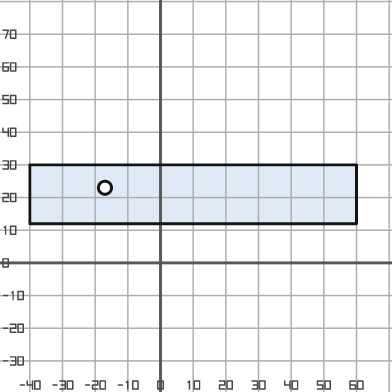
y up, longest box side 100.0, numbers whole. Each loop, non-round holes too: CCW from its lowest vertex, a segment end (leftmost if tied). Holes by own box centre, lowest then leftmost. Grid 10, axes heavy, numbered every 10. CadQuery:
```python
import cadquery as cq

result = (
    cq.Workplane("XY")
    .moveTo(-40.0, 12.0)
    .lineTo(60.0, 12.0)
    .lineTo(60.0, 30.0)
    .lineTo(-40.0, 30.0)
    .close()
    .moveTo(-17.0, 23.0)
    .circle(2.0)
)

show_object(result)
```